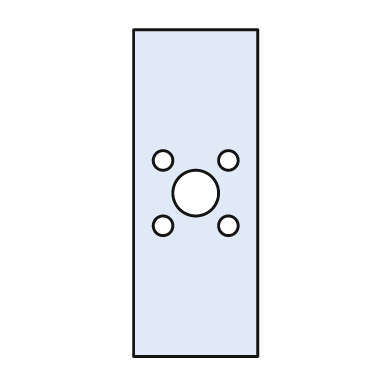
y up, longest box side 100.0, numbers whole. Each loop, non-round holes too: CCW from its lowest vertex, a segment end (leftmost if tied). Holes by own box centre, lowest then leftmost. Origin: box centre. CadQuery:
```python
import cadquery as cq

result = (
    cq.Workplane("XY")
    .moveTo(-19.0, -50.0)
    .lineTo(19.0, -50.0)
    .lineTo(19.0, 50.0)
    .lineTo(-19.0, 50.0)
    .close()
    .moveTo(-10.0, -10.0)
    .circle(3.0)
    .moveTo(10.0, -10.0)
    .circle(3.0)
    .moveTo(0.0, 0.0)
    .circle(7.0)
    .moveTo(-10.0, 10.0)
    .circle(3.0)
    .moveTo(10.0, 10.0)
    .circle(3.0)
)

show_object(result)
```